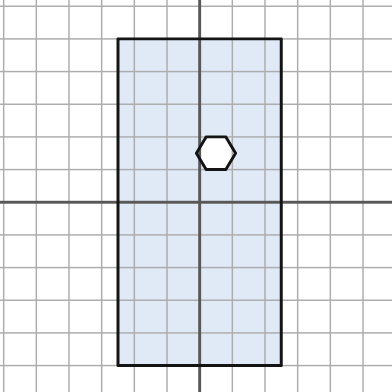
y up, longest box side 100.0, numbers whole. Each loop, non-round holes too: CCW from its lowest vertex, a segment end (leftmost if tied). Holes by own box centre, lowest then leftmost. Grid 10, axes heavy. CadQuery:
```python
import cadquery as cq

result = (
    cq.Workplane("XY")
    .moveTo(-25.0, -50.0)
    .lineTo(25.0, -50.0)
    .lineTo(25.0, 50.0)
    .lineTo(-25.0, 50.0)
    .close()
    .moveTo(2.0, 10.0)
    .lineTo(8.0, 10.0)
    .lineTo(11.0, 15.0)
    .lineTo(8.0, 20.0)
    .lineTo(2.0, 20.0)
    .lineTo(-1.0, 15.0)
    .close()
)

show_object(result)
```